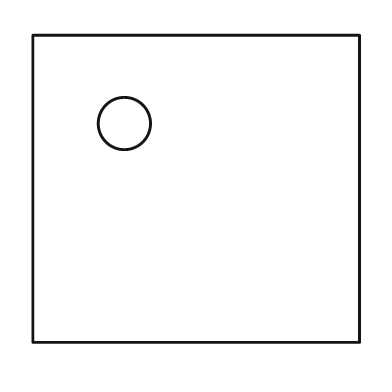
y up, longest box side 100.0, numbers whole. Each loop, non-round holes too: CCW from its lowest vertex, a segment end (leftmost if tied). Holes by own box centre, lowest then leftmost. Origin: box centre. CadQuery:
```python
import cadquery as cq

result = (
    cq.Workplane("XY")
    .moveTo(-50.0, -47.0)
    .lineTo(50.0, -47.0)
    .lineTo(50.0, 47.0)
    .lineTo(-50.0, 47.0)
    .close()
    .moveTo(-22.0, 20.0)
    .circle(8.0)
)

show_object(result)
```